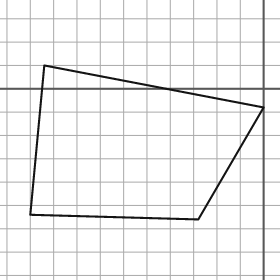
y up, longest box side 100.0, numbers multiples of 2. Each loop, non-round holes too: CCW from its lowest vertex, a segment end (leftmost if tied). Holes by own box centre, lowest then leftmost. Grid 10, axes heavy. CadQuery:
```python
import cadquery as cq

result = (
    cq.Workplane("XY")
    .moveTo(-28.0, -56.0)
    .lineTo(0.0, -8.0)
    .lineTo(-94.0, 10.0)
    .lineTo(-100.0, -54.0)
    .close()
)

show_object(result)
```